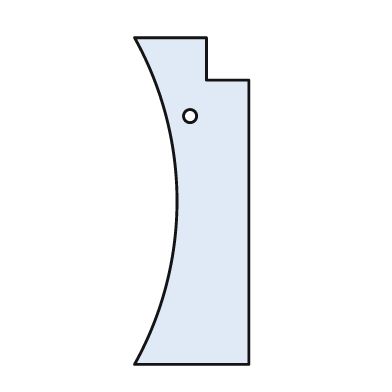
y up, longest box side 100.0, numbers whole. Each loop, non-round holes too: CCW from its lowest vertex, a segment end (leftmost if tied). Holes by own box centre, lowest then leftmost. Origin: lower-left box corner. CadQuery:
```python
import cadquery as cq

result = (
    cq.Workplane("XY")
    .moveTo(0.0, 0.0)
    .lineTo(35.0, 0.0)
    .lineTo(35.0, 87.0)
    .lineTo(22.0, 87.0)
    .lineTo(22.0, 100.0)
    .lineTo(0.0, 100.0)
    .threePointArc((13.0, 50.0), (0.0, 0.0))
    .close()
    .moveTo(17.0, 76.0)
    .circle(2.0)
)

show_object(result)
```